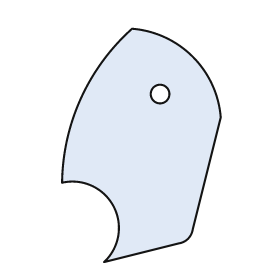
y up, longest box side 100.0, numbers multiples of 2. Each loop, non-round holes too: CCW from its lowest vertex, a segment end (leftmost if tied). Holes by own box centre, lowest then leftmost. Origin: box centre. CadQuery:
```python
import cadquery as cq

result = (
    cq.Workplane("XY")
    .moveTo(-16.0, -50.0)
    .lineTo(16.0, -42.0)
    .threePointArc((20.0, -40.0), (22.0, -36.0))
    .lineTo(34.0, 12.0)
    .threePointArc((22.0, 38.0), (-4.0, 50.0))
    .threePointArc((-26.0, 20.0), (-34.0, -16.0))
    .threePointArc((-12.0, -26.0), (-16.0, -50.0))
    .close()
    .moveTo(8.0, 22.0)
    .circle(4.0)
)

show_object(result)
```